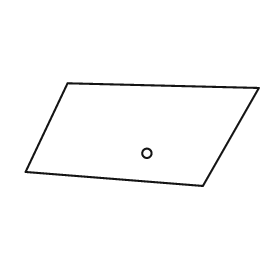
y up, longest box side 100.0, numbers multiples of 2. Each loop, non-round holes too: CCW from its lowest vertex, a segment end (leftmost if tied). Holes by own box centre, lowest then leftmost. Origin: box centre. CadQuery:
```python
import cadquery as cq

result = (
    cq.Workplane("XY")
    .moveTo(26.0, -22.0)
    .lineTo(50.0, 20.0)
    .lineTo(-32.0, 22.0)
    .lineTo(-50.0, -16.0)
    .close()
    .moveTo(2.0, -8.0)
    .circle(2.0)
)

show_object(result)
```